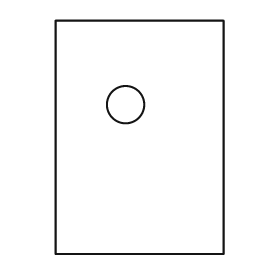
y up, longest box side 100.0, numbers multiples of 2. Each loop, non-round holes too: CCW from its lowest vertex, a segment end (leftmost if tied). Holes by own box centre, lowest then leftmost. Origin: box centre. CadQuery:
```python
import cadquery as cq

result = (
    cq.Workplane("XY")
    .moveTo(-36.0, -50.0)
    .lineTo(36.0, -50.0)
    .lineTo(36.0, 50.0)
    .lineTo(-36.0, 50.0)
    .close()
    .moveTo(-6.0, 14.0)
    .circle(8.0)
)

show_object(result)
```